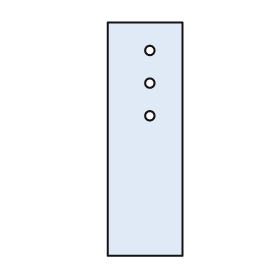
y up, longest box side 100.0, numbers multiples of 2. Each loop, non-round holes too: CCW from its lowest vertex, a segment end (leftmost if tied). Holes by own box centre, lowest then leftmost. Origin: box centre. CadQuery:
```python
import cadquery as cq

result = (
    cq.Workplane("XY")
    .moveTo(-16.0, -50.0)
    .lineTo(16.0, -50.0)
    .lineTo(16.0, 50.0)
    .lineTo(-16.0, 50.0)
    .close()
    .moveTo(2.0, 10.0)
    .circle(2.0)
    .moveTo(2.0, 24.0)
    .circle(2.0)
    .moveTo(2.0, 38.0)
    .circle(2.0)
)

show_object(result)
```